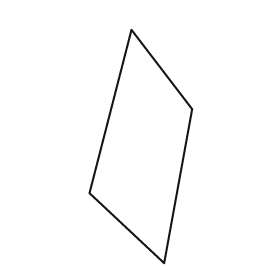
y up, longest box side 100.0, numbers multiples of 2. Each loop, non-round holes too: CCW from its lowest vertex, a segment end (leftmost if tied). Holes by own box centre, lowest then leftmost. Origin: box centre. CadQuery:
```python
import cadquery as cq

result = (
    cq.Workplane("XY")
    .moveTo(10.0, -50.0)
    .lineTo(22.0, 16.0)
    .lineTo(-4.0, 50.0)
    .lineTo(-22.0, -20.0)
    .close()
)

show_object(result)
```